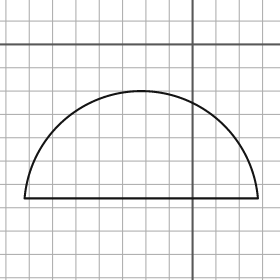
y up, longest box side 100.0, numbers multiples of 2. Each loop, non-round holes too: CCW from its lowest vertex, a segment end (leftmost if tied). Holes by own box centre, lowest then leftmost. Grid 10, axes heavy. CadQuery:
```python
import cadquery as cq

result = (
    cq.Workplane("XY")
    .moveTo(-72.0, -66.0)
    .lineTo(28.0, -66.0)
    .threePointArc((-22.0, -20.0), (-72.0, -66.0))
    .close()
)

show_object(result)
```